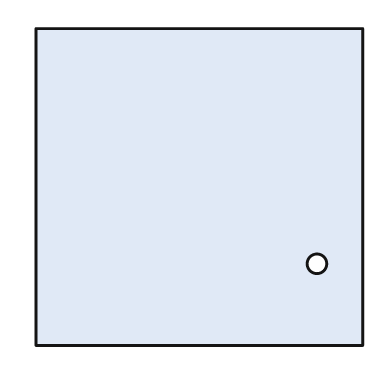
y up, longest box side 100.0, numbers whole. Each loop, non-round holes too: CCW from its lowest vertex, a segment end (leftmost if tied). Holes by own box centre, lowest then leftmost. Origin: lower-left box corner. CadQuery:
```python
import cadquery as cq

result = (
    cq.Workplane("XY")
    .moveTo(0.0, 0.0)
    .lineTo(100.0, 0.0)
    .lineTo(100.0, 97.0)
    .lineTo(0.0, 97.0)
    .close()
    .moveTo(86.0, 25.0)
    .circle(3.0)
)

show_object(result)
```